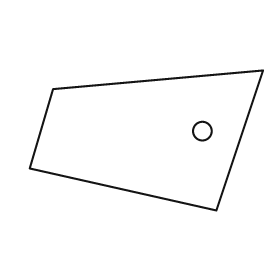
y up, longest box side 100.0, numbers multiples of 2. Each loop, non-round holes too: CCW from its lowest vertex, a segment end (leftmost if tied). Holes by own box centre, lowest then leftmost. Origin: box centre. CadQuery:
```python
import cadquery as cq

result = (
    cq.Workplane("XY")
    .moveTo(30.0, -30.0)
    .lineTo(50.0, 30.0)
    .lineTo(-40.0, 22.0)
    .lineTo(-50.0, -12.0)
    .close()
    .moveTo(24.0, 4.0)
    .circle(4.0)
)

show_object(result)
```